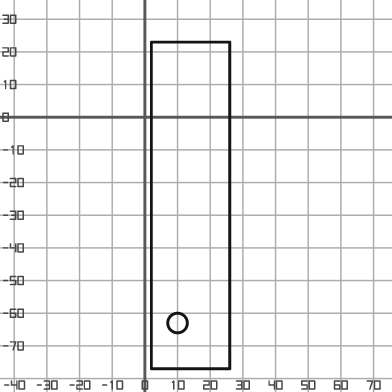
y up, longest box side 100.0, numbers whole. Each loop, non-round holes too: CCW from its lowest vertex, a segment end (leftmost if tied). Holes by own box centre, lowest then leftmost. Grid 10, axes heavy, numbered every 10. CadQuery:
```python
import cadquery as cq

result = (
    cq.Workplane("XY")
    .moveTo(2.0, -77.0)
    .lineTo(26.0, -77.0)
    .lineTo(26.0, 23.0)
    .lineTo(2.0, 23.0)
    .close()
    .moveTo(10.0, -63.0)
    .circle(3.0)
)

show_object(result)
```